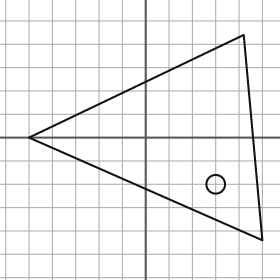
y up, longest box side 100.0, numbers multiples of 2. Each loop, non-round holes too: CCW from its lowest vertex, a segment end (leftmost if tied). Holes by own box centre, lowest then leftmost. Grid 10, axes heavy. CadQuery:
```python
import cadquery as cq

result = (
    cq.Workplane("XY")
    .moveTo(50.0, -44.0)
    .lineTo(42.0, 44.0)
    .lineTo(-50.0, 0.0)
    .close()
    .moveTo(30.0, -20.0)
    .circle(4.0)
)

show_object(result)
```